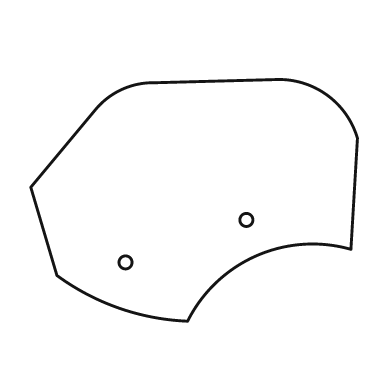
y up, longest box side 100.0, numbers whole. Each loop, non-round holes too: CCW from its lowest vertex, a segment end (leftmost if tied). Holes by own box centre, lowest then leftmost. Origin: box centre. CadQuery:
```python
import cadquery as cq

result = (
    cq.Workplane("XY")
    .moveTo(-2.0, -37.0)
    .threePointArc((19.0, -17.0), (48.0, -15.0))
    .lineTo(50.0, 19.0)
    .threePointArc((41.0, 32.0), (26.0, 37.0))
    .lineTo(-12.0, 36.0)
    .threePointArc((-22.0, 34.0), (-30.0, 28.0))
    .lineTo(-50.0, 4.0)
    .lineTo(-42.0, -23.0)
    .threePointArc((-23.0, -33.0), (-2.0, -37.0))
    .close()
    .moveTo(-21.0, -19.0)
    .circle(2.0)
    .moveTo(16.0, -6.0)
    .circle(2.0)
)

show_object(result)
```